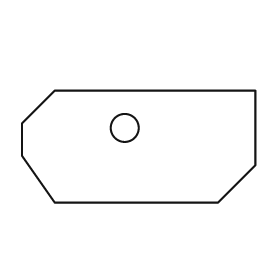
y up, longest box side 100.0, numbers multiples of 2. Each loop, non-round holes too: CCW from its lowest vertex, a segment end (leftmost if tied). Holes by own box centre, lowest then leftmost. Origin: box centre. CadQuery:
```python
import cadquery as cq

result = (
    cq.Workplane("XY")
    .moveTo(-36.0, -24.0)
    .lineTo(34.0, -24.0)
    .lineTo(50.0, -8.0)
    .lineTo(50.0, 24.0)
    .lineTo(-36.0, 24.0)
    .lineTo(-50.0, 10.0)
    .lineTo(-50.0, -4.0)
    .close()
    .moveTo(-6.0, 8.0)
    .circle(6.0)
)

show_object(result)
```